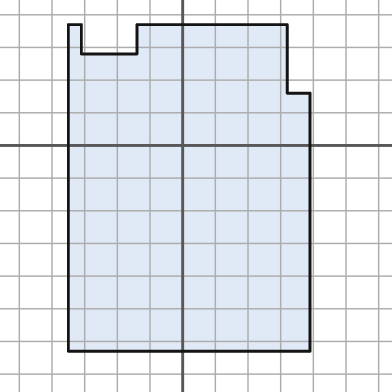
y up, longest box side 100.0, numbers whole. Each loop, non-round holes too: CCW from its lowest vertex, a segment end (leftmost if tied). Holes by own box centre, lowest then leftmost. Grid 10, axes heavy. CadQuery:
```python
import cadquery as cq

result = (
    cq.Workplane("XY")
    .moveTo(-35.0, -63.0)
    .lineTo(39.0, -63.0)
    .lineTo(39.0, 16.0)
    .lineTo(32.0, 16.0)
    .lineTo(32.0, 37.0)
    .lineTo(-14.0, 37.0)
    .lineTo(-14.0, 28.0)
    .lineTo(-31.0, 28.0)
    .lineTo(-31.0, 37.0)
    .lineTo(-35.0, 37.0)
    .close()
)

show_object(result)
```